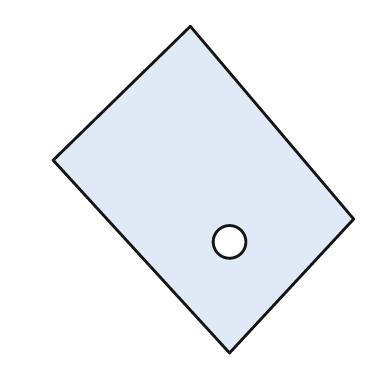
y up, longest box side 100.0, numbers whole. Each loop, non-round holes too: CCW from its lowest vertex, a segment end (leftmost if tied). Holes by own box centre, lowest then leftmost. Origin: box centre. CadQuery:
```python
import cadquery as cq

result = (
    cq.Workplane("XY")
    .moveTo(8.0, -50.0)
    .lineTo(46.0, -9.0)
    .lineTo(-4.0, 50.0)
    .lineTo(-46.0, 9.0)
    .close()
    .moveTo(8.0, -16.0)
    .circle(5.0)
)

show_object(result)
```